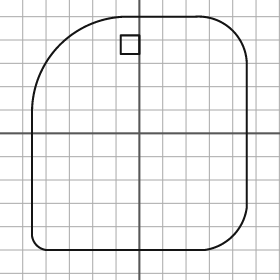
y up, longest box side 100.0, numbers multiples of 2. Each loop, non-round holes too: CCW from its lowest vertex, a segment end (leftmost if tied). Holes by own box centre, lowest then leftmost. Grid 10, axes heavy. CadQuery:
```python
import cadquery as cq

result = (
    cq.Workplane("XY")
    .moveTo(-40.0, -50.0)
    .lineTo(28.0, -50.0)
    .threePointArc((40.0, -44.0), (46.0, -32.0))
    .lineTo(46.0, 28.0)
    .threePointArc((40.0, 44.0), (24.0, 50.0))
    .lineTo(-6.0, 50.0)
    .threePointArc((-34.0, 38.0), (-46.0, 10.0))
    .lineTo(-46.0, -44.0)
    .threePointArc((-44.0, -48.0), (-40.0, -50.0))
    .close()
    .moveTo(-8.0, 34.0)
    .lineTo(0.0, 34.0)
    .lineTo(0.0, 42.0)
    .lineTo(-8.0, 42.0)
    .close()
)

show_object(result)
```